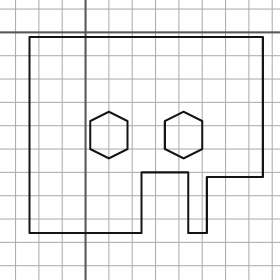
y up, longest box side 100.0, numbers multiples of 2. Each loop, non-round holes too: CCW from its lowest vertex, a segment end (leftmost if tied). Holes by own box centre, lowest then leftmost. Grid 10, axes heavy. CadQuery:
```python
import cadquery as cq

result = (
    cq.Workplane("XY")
    .moveTo(-24.0, -86.0)
    .lineTo(24.0, -86.0)
    .lineTo(24.0, -60.0)
    .lineTo(44.0, -60.0)
    .lineTo(44.0, -86.0)
    .lineTo(52.0, -86.0)
    .lineTo(52.0, -62.0)
    .lineTo(76.0, -62.0)
    .lineTo(76.0, -2.0)
    .lineTo(-24.0, -2.0)
    .close()
    .moveTo(10.0, -54.0)
    .lineTo(18.0, -50.0)
    .lineTo(18.0, -38.0)
    .lineTo(10.0, -34.0)
    .lineTo(2.0, -38.0)
    .lineTo(2.0, -50.0)
    .close()
    .moveTo(42.0, -54.0)
    .lineTo(50.0, -50.0)
    .lineTo(50.0, -38.0)
    .lineTo(42.0, -34.0)
    .lineTo(34.0, -38.0)
    .lineTo(34.0, -50.0)
    .close()
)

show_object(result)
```